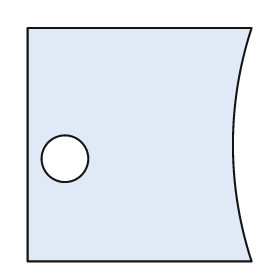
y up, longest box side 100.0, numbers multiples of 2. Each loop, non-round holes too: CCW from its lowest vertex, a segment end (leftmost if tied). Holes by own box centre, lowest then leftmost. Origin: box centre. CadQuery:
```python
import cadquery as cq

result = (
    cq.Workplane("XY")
    .moveTo(-48.0, -50.0)
    .lineTo(48.0, -50.0)
    .threePointArc((40.0, 0.0), (48.0, 50.0))
    .lineTo(-48.0, 50.0)
    .close()
    .moveTo(-32.0, -6.0)
    .circle(10.0)
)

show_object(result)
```